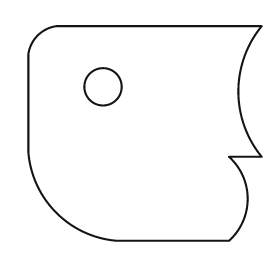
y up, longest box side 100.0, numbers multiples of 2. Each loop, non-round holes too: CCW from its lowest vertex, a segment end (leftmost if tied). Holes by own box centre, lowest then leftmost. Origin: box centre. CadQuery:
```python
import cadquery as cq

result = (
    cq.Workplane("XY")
    .moveTo(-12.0, -46.0)
    .lineTo(36.0, -46.0)
    .threePointArc((44.0, -28.0), (36.0, -10.0))
    .lineTo(50.0, -10.0)
    .threePointArc((40.0, 18.0), (50.0, 46.0))
    .lineTo(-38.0, 46.0)
    .threePointArc((-46.0, 42.0), (-50.0, 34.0))
    .lineTo(-50.0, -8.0)
    .threePointArc((-38.0, -34.0), (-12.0, -46.0))
    .close()
    .moveTo(-18.0, 20.0)
    .circle(8.0)
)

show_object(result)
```